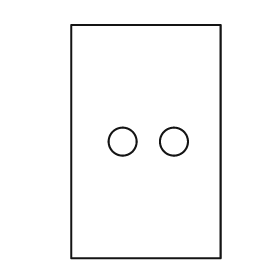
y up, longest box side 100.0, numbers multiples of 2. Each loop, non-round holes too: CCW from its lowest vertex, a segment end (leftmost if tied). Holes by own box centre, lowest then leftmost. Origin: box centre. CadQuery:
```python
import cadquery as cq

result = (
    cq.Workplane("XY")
    .moveTo(-32.0, -50.0)
    .lineTo(32.0, -50.0)
    .lineTo(32.0, 50.0)
    .lineTo(-32.0, 50.0)
    .close()
    .moveTo(-10.0, 0.0)
    .circle(6.0)
    .moveTo(12.0, 0.0)
    .circle(6.0)
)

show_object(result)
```